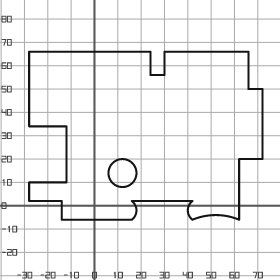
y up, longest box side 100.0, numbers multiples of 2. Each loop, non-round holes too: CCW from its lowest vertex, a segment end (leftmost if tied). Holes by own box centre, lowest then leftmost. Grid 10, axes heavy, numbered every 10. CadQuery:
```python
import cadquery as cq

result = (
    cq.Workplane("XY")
    .moveTo(-14.0, -6.0)
    .lineTo(16.0, -6.0)
    .threePointArc((18.0, -2.0), (16.0, 2.0))
    .lineTo(42.0, 2.0)
    .threePointArc((40.0, -2.0), (42.0, -6.0))
    .threePointArc((52.0, -4.0), (62.0, -6.0))
    .lineTo(62.0, 20.0)
    .lineTo(72.0, 20.0)
    .lineTo(72.0, 50.0)
    .lineTo(66.0, 50.0)
    .lineTo(66.0, 66.0)
    .lineTo(30.0, 66.0)
    .lineTo(30.0, 56.0)
    .lineTo(24.0, 56.0)
    .lineTo(24.0, 66.0)
    .lineTo(-28.0, 66.0)
    .lineTo(-28.0, 34.0)
    .lineTo(-12.0, 34.0)
    .lineTo(-12.0, 10.0)
    .lineTo(-28.0, 10.0)
    .lineTo(-28.0, 2.0)
    .lineTo(-14.0, 2.0)
    .close()
    .moveTo(12.0, 14.0)
    .circle(6.0)
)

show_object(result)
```